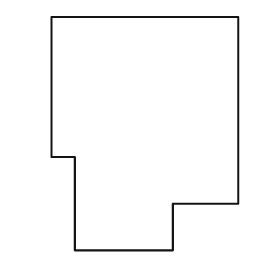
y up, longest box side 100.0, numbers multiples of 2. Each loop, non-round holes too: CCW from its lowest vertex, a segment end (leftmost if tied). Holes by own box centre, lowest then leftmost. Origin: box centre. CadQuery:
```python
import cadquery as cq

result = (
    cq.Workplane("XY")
    .moveTo(-30.0, -50.0)
    .lineTo(12.0, -50.0)
    .lineTo(12.0, -30.0)
    .lineTo(40.0, -30.0)
    .lineTo(40.0, 50.0)
    .lineTo(-40.0, 50.0)
    .lineTo(-40.0, -10.0)
    .lineTo(-30.0, -10.0)
    .close()
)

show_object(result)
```